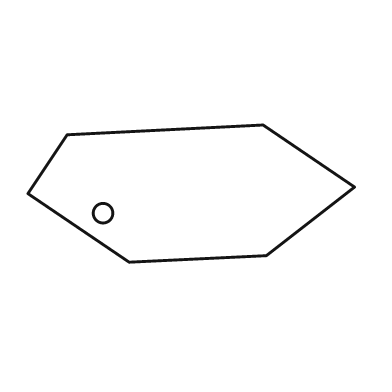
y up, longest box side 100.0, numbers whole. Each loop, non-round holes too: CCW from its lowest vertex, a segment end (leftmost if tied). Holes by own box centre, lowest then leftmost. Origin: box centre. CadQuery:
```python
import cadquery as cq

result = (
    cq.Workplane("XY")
    .moveTo(-19.0, -21.0)
    .lineTo(23.0, -19.0)
    .lineTo(50.0, 2.0)
    .lineTo(22.0, 21.0)
    .lineTo(-38.0, 18.0)
    .lineTo(-50.0, 0.0)
    .close()
    .moveTo(-27.0, -6.0)
    .circle(3.0)
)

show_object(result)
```